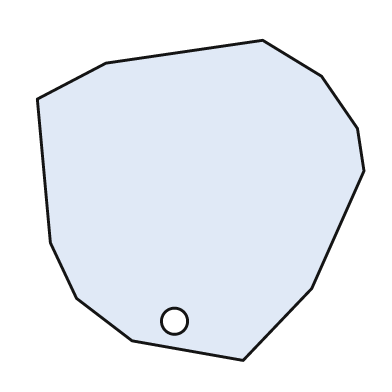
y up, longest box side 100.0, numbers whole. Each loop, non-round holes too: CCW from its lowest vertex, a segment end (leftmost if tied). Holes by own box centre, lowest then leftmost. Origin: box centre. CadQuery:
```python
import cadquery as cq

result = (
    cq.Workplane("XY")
    .moveTo(13.0, -49.0)
    .lineTo(34.0, -27.0)
    .lineTo(50.0, 9.0)
    .lineTo(48.0, 22.0)
    .lineTo(37.0, 38.0)
    .lineTo(19.0, 49.0)
    .lineTo(-29.0, 42.0)
    .lineTo(-50.0, 31.0)
    .lineTo(-46.0, -13.0)
    .lineTo(-38.0, -30.0)
    .lineTo(-21.0, -43.0)
    .close()
    .moveTo(-8.0, -37.0)
    .circle(4.0)
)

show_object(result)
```